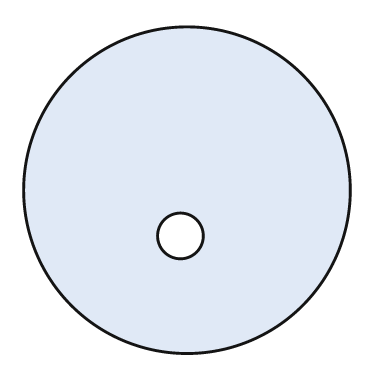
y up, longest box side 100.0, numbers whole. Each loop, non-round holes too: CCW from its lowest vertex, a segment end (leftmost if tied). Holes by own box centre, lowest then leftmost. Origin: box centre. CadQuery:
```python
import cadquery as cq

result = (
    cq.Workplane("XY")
    .moveTo(0.0, 0.0)
    .circle(50.0)
    .moveTo(-2.0, -14.0)
    .circle(7.0)
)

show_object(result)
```